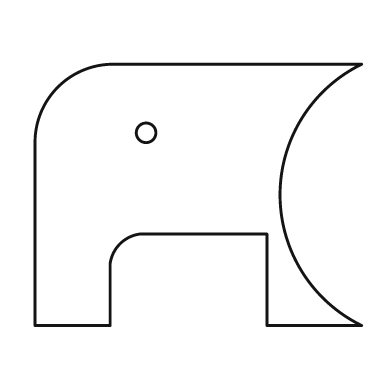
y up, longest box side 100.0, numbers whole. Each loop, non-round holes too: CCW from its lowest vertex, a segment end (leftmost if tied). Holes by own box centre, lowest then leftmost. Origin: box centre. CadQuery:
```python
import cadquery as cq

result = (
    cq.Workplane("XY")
    .moveTo(-50.0, -40.0)
    .lineTo(-27.0, -40.0)
    .lineTo(-27.0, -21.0)
    .threePointArc((-24.0, -15.0), (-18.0, -12.0))
    .lineTo(21.0, -12.0)
    .lineTo(21.0, -40.0)
    .lineTo(50.0, -40.0)
    .threePointArc((25.0, 0.0), (50.0, 40.0))
    .lineTo(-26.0, 40.0)
    .threePointArc((-43.0, 33.0), (-50.0, 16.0))
    .close()
    .moveTo(-16.0, 19.0)
    .circle(3.0)
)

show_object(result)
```